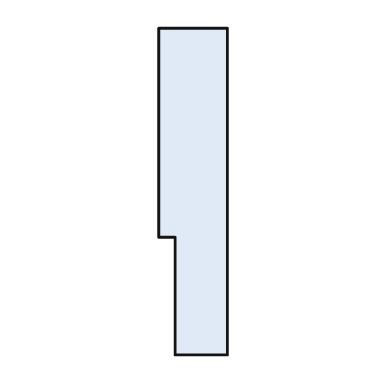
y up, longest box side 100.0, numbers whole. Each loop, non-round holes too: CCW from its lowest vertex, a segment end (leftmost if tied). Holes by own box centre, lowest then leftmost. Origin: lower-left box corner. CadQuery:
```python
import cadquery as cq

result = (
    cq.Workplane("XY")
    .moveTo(5.0, 0.0)
    .lineTo(21.0, 0.0)
    .lineTo(21.0, 100.0)
    .lineTo(0.0, 100.0)
    .lineTo(0.0, 36.0)
    .lineTo(5.0, 36.0)
    .close()
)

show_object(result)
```